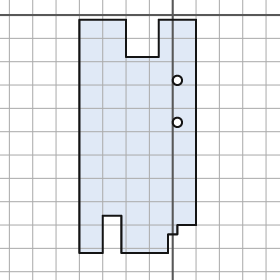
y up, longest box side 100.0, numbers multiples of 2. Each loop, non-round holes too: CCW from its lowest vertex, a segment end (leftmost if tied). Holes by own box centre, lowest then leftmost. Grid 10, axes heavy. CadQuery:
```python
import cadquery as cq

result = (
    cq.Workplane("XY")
    .moveTo(-40.0, -102.0)
    .lineTo(-30.0, -102.0)
    .lineTo(-30.0, -86.0)
    .lineTo(-22.0, -86.0)
    .lineTo(-22.0, -102.0)
    .lineTo(-2.0, -102.0)
    .lineTo(-2.0, -94.0)
    .lineTo(2.0, -94.0)
    .lineTo(2.0, -90.0)
    .lineTo(10.0, -90.0)
    .lineTo(10.0, -2.0)
    .lineTo(-6.0, -2.0)
    .lineTo(-6.0, -18.0)
    .lineTo(-20.0, -18.0)
    .lineTo(-20.0, -2.0)
    .lineTo(-40.0, -2.0)
    .close()
    .moveTo(2.0, -46.0)
    .circle(2.0)
    .moveTo(2.0, -28.0)
    .circle(2.0)
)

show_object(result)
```